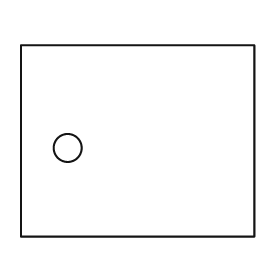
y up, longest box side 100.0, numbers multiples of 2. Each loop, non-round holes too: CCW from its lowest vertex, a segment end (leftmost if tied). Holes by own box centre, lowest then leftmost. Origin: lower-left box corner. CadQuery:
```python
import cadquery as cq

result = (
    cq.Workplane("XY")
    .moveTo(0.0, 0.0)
    .lineTo(100.0, 0.0)
    .lineTo(100.0, 82.0)
    .lineTo(0.0, 82.0)
    .close()
    .moveTo(20.0, 38.0)
    .circle(6.0)
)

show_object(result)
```